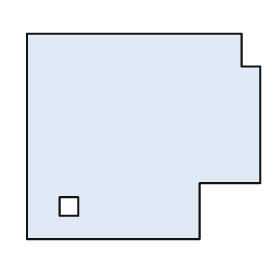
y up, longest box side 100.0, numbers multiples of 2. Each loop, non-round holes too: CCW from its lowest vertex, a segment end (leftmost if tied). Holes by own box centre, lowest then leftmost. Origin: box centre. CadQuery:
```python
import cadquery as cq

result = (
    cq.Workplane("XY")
    .moveTo(-50.0, -44.0)
    .lineTo(24.0, -44.0)
    .lineTo(24.0, -20.0)
    .lineTo(50.0, -20.0)
    .lineTo(50.0, 30.0)
    .lineTo(42.0, 30.0)
    .lineTo(42.0, 44.0)
    .lineTo(-50.0, 44.0)
    .close()
    .moveTo(-36.0, -34.0)
    .lineTo(-28.0, -34.0)
    .lineTo(-28.0, -26.0)
    .lineTo(-36.0, -26.0)
    .close()
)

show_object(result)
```